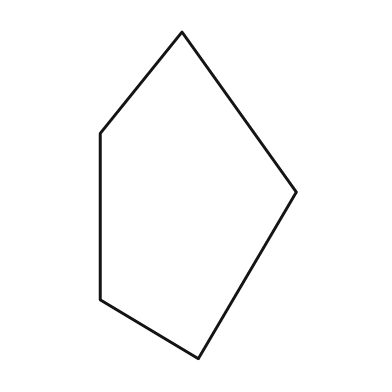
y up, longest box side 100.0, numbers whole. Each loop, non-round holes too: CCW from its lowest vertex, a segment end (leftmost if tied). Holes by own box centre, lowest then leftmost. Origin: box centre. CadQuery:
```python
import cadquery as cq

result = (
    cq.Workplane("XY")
    .moveTo(0.0, -50.0)
    .lineTo(30.0, 1.0)
    .lineTo(-5.0, 50.0)
    .lineTo(-30.0, 19.0)
    .lineTo(-30.0, -32.0)
    .close()
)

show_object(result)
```